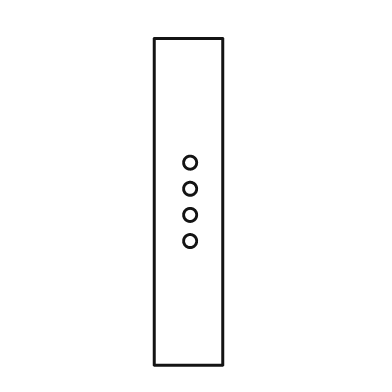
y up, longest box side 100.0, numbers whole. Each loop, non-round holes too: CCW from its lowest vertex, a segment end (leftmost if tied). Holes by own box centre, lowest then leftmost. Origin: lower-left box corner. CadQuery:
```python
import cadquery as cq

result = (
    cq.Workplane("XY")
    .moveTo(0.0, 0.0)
    .lineTo(21.0, 0.0)
    .lineTo(21.0, 100.0)
    .lineTo(0.0, 100.0)
    .close()
    .moveTo(11.0, 38.0)
    .circle(2.0)
    .moveTo(11.0, 46.0)
    .circle(2.0)
    .moveTo(11.0, 54.0)
    .circle(2.0)
    .moveTo(11.0, 62.0)
    .circle(2.0)
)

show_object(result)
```